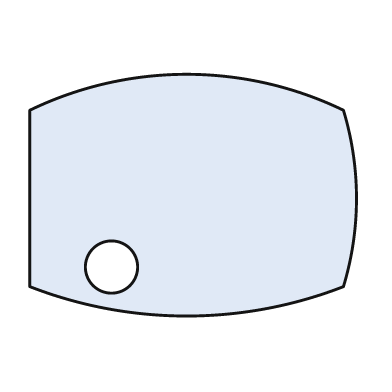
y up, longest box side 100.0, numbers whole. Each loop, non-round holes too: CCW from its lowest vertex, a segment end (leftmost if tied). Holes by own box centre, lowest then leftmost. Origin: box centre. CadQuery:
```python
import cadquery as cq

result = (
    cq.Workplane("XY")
    .moveTo(-50.0, -28.0)
    .threePointArc((-2.0, -37.0), (46.0, -28.0))
    .threePointArc((50.0, -1.0), (46.0, 26.0))
    .threePointArc((-2.0, 37.0), (-50.0, 26.0))
    .close()
    .moveTo(-25.0, -22.0)
    .circle(8.0)
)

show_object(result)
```